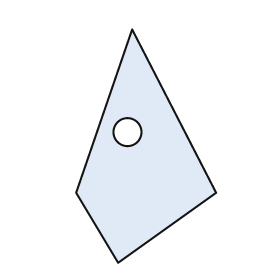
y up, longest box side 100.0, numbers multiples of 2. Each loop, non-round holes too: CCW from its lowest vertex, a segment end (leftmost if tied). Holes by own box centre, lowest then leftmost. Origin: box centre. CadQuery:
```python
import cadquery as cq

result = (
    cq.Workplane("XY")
    .moveTo(-12.0, -50.0)
    .lineTo(30.0, -20.0)
    .lineTo(-6.0, 50.0)
    .lineTo(-30.0, -20.0)
    .close()
    .moveTo(-8.0, 6.0)
    .circle(6.0)
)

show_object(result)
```